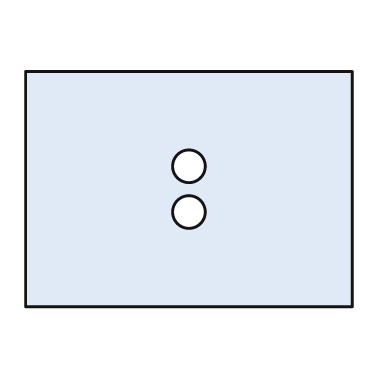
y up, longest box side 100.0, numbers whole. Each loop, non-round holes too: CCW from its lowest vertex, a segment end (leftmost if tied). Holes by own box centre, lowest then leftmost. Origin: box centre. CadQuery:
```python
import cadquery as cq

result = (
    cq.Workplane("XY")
    .moveTo(-50.0, -36.0)
    .lineTo(50.0, -36.0)
    .lineTo(50.0, 36.0)
    .lineTo(-50.0, 36.0)
    .close()
    .moveTo(0.0, -7.0)
    .circle(5.0)
    .moveTo(0.0, 7.0)
    .circle(5.0)
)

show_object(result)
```